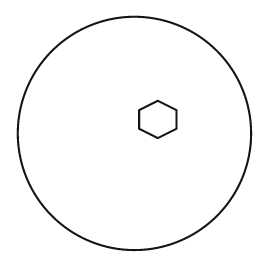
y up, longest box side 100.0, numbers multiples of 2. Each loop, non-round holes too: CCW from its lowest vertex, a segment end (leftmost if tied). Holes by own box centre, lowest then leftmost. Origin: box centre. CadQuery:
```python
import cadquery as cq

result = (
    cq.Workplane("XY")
    .moveTo(0.0, 0.0)
    .circle(50.0)
    .moveTo(10.0, -2.0)
    .lineTo(18.0, 2.0)
    .lineTo(18.0, 10.0)
    .lineTo(10.0, 14.0)
    .lineTo(2.0, 10.0)
    .lineTo(2.0, 2.0)
    .close()
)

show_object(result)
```